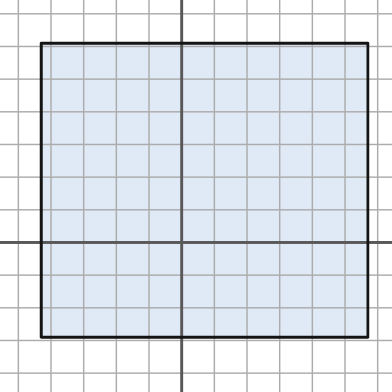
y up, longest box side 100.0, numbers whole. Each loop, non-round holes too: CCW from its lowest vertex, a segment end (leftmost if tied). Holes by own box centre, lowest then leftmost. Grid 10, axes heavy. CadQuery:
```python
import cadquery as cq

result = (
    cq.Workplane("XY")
    .moveTo(-43.0, -29.0)
    .lineTo(57.0, -29.0)
    .lineTo(57.0, 61.0)
    .lineTo(-43.0, 61.0)
    .close()
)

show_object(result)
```